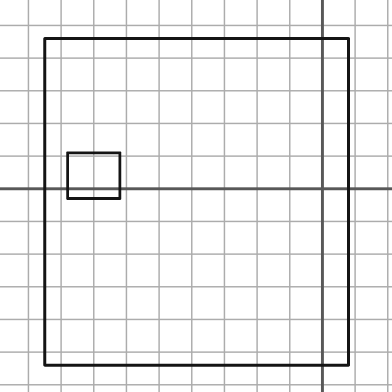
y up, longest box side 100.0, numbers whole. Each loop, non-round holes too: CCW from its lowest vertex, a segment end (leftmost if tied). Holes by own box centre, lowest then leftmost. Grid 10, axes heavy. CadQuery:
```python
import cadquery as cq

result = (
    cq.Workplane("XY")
    .moveTo(-85.0, -54.0)
    .lineTo(8.0, -54.0)
    .lineTo(8.0, 46.0)
    .lineTo(-85.0, 46.0)
    .close()
    .moveTo(-78.0, -3.0)
    .lineTo(-62.0, -3.0)
    .lineTo(-62.0, 11.0)
    .lineTo(-78.0, 11.0)
    .close()
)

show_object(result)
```